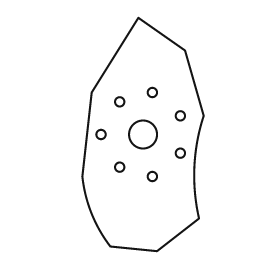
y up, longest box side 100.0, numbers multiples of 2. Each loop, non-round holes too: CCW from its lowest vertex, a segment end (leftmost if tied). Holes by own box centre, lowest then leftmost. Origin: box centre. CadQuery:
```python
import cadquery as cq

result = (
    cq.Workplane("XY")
    .moveTo(6.0, -50.0)
    .lineTo(24.0, -36.0)
    .threePointArc((22.0, -14.0), (26.0, 8.0))
    .lineTo(18.0, 36.0)
    .lineTo(-2.0, 50.0)
    .lineTo(-22.0, 18.0)
    .lineTo(-26.0, -18.0)
    .threePointArc((-22.0, -34.0), (-14.0, -48.0))
    .close()
    .moveTo(4.0, -18.0)
    .circle(2.0)
    .moveTo(-10.0, -14.0)
    .circle(2.0)
    .moveTo(16.0, -8.0)
    .circle(2.0)
    .moveTo(-18.0, 0.0)
    .circle(2.0)
    .moveTo(0.0, 0.0)
    .circle(6.0)
    .moveTo(16.0, 8.0)
    .circle(2.0)
    .moveTo(-10.0, 14.0)
    .circle(2.0)
    .moveTo(4.0, 18.0)
    .circle(2.0)
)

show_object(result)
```